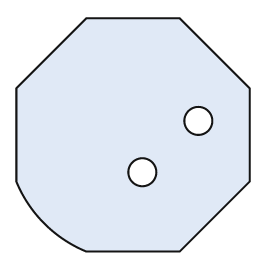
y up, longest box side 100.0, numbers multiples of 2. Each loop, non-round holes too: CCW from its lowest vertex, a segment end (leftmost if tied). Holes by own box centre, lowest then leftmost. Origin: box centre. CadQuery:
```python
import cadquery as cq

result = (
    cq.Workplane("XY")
    .moveTo(-20.0, -50.0)
    .lineTo(20.0, -50.0)
    .lineTo(50.0, -20.0)
    .lineTo(50.0, 20.0)
    .lineTo(20.0, 50.0)
    .lineTo(-20.0, 50.0)
    .lineTo(-50.0, 20.0)
    .lineTo(-50.0, -20.0)
    .threePointArc((-38.0, -38.0), (-20.0, -50.0))
    .close()
    .moveTo(4.0, -16.0)
    .circle(6.0)
    .moveTo(28.0, 6.0)
    .circle(6.0)
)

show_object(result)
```